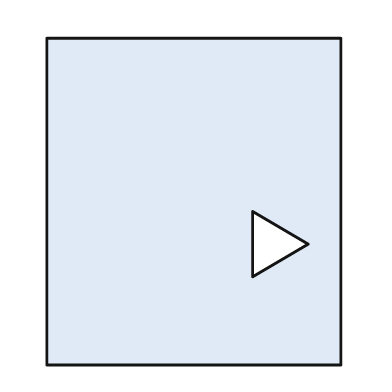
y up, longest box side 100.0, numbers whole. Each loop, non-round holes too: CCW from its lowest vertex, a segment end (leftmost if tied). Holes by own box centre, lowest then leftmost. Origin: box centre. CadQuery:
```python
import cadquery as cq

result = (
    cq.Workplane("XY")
    .moveTo(-45.0, -50.0)
    .lineTo(45.0, -50.0)
    .lineTo(45.0, 50.0)
    .lineTo(-45.0, 50.0)
    .close()
    .moveTo(18.0, -23.0)
    .lineTo(35.0, -13.0)
    .lineTo(18.0, -3.0)
    .close()
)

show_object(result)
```